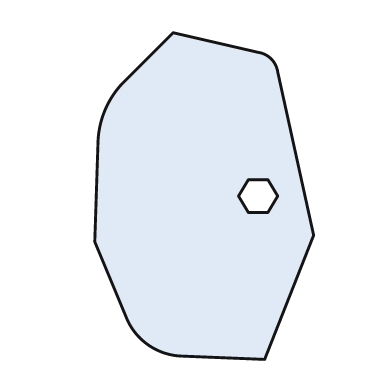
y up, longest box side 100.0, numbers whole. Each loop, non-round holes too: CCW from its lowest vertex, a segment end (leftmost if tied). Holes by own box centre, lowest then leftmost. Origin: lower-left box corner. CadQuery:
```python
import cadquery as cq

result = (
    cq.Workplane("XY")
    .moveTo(52.0, 0.0)
    .lineTo(67.0, 38.0)
    .lineTo(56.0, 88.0)
    .threePointArc((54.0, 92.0), (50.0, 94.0))
    .lineTo(24.0, 100.0)
    .lineTo(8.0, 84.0)
    .threePointArc((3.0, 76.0), (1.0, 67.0))
    .lineTo(0.0, 36.0)
    .lineTo(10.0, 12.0)
    .threePointArc((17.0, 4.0), (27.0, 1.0))
    .close()
    .moveTo(47.0, 45.0)
    .lineTo(53.0, 45.0)
    .lineTo(56.0, 50.0)
    .lineTo(53.0, 55.0)
    .lineTo(47.0, 55.0)
    .lineTo(44.0, 50.0)
    .close()
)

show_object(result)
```